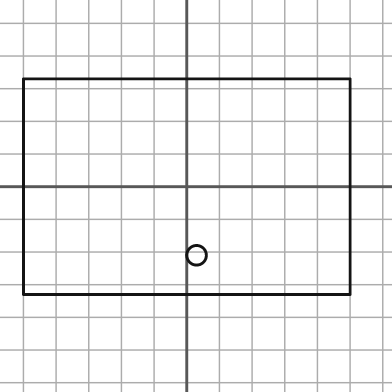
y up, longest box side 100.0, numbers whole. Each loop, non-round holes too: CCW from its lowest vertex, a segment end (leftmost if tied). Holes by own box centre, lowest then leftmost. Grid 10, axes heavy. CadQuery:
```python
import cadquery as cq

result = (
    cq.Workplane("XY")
    .moveTo(-50.0, -33.0)
    .lineTo(50.0, -33.0)
    .lineTo(50.0, 33.0)
    .lineTo(-50.0, 33.0)
    .close()
    .moveTo(3.0, -21.0)
    .circle(3.0)
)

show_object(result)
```